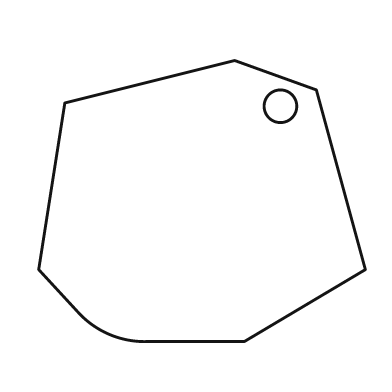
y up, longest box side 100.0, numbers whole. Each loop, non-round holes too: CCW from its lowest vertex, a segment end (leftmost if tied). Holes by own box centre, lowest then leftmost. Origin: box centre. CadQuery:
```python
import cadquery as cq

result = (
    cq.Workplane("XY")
    .moveTo(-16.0, -43.0)
    .lineTo(13.0, -43.0)
    .lineTo(50.0, -21.0)
    .lineTo(35.0, 34.0)
    .lineTo(10.0, 43.0)
    .lineTo(-42.0, 30.0)
    .lineTo(-50.0, -21.0)
    .lineTo(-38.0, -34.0)
    .threePointArc((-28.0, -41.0), (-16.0, -43.0))
    .close()
    .moveTo(24.0, 29.0)
    .circle(5.0)
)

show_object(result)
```